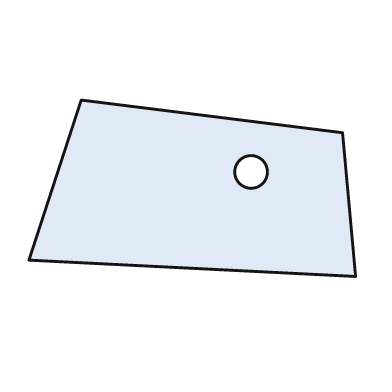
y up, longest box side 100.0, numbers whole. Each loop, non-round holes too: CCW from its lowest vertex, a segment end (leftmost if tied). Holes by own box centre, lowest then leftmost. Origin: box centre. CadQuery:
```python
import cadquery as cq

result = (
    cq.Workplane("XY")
    .moveTo(50.0, -27.0)
    .lineTo(46.0, 17.0)
    .lineTo(-34.0, 27.0)
    .lineTo(-50.0, -22.0)
    .close()
    .moveTo(18.0, 5.0)
    .circle(5.0)
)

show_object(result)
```